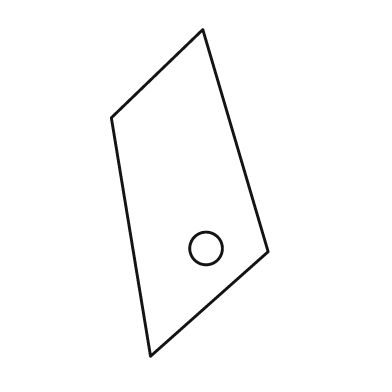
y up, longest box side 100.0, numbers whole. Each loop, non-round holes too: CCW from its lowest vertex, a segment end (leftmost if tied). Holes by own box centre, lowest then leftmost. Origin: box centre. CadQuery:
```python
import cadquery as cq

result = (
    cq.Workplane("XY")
    .moveTo(-12.0, -50.0)
    .lineTo(24.0, -18.0)
    .lineTo(4.0, 50.0)
    .lineTo(-24.0, 23.0)
    .close()
    .moveTo(5.0, -17.0)
    .circle(5.0)
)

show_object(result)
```